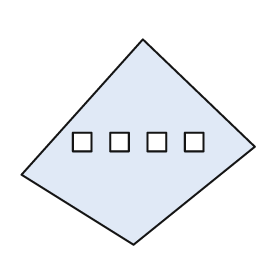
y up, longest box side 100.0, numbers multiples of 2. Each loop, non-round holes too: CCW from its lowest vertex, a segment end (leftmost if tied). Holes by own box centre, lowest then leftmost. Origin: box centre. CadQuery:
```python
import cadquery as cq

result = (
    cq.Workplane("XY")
    .moveTo(-2.0, -44.0)
    .lineTo(50.0, -2.0)
    .lineTo(2.0, 44.0)
    .lineTo(-50.0, -14.0)
    .close()
    .moveTo(-28.0, -4.0)
    .lineTo(-20.0, -4.0)
    .lineTo(-20.0, 4.0)
    .lineTo(-28.0, 4.0)
    .close()
    .moveTo(-12.0, -4.0)
    .lineTo(-4.0, -4.0)
    .lineTo(-4.0, 4.0)
    .lineTo(-12.0, 4.0)
    .close()
    .moveTo(4.0, -4.0)
    .lineTo(12.0, -4.0)
    .lineTo(12.0, 4.0)
    .lineTo(4.0, 4.0)
    .close()
    .moveTo(20.0, -4.0)
    .lineTo(28.0, -4.0)
    .lineTo(28.0, 4.0)
    .lineTo(20.0, 4.0)
    .close()
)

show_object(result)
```